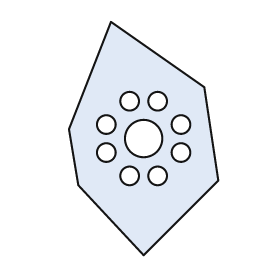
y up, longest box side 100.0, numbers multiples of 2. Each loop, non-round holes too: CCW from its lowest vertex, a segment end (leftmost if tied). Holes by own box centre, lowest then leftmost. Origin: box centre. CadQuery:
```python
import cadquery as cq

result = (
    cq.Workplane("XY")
    .moveTo(0.0, -50.0)
    .lineTo(32.0, -18.0)
    .lineTo(26.0, 22.0)
    .lineTo(-14.0, 50.0)
    .lineTo(-32.0, 4.0)
    .lineTo(-28.0, -20.0)
    .close()
    .moveTo(-6.0, -16.0)
    .circle(4.0)
    .moveTo(6.0, -16.0)
    .circle(4.0)
    .moveTo(-16.0, -6.0)
    .circle(4.0)
    .moveTo(16.0, -6.0)
    .circle(4.0)
    .moveTo(0.0, 0.0)
    .circle(8.0)
    .moveTo(-16.0, 6.0)
    .circle(4.0)
    .moveTo(16.0, 6.0)
    .circle(4.0)
    .moveTo(-6.0, 16.0)
    .circle(4.0)
    .moveTo(6.0, 16.0)
    .circle(4.0)
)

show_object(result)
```